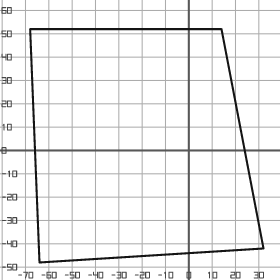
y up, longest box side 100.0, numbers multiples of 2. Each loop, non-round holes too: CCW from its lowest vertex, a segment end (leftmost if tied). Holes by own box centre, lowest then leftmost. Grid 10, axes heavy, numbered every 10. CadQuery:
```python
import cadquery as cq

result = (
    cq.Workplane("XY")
    .moveTo(-64.0, -48.0)
    .lineTo(32.0, -42.0)
    .lineTo(14.0, 52.0)
    .lineTo(-68.0, 52.0)
    .close()
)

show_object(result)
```